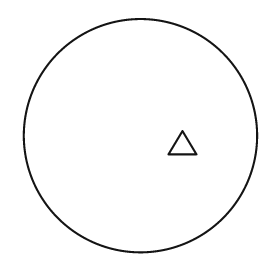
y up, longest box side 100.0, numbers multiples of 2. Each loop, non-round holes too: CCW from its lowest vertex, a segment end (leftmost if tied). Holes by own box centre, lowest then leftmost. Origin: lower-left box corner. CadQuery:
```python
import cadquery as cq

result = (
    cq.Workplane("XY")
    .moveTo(50.0, 50.0)
    .circle(50.0)
    .moveTo(62.0, 42.0)
    .lineTo(74.0, 42.0)
    .lineTo(68.0, 52.0)
    .close()
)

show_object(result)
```